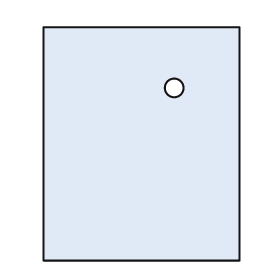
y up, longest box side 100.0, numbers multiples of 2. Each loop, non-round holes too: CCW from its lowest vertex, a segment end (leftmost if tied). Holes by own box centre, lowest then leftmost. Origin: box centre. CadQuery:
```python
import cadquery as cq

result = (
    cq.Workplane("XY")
    .moveTo(-42.0, -50.0)
    .lineTo(42.0, -50.0)
    .lineTo(42.0, 50.0)
    .lineTo(-42.0, 50.0)
    .close()
    .moveTo(14.0, 24.0)
    .circle(4.0)
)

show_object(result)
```